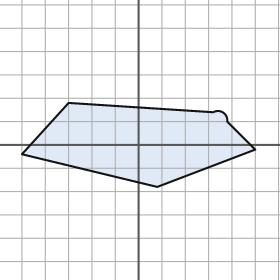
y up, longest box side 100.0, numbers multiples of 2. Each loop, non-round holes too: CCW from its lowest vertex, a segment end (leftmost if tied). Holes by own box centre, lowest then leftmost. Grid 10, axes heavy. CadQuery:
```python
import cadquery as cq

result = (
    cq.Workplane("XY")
    .moveTo(8.0, -18.0)
    .lineTo(50.0, -2.0)
    .lineTo(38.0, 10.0)
    .threePointArc((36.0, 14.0), (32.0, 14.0))
    .lineTo(-30.0, 18.0)
    .lineTo(-50.0, -4.0)
    .close()
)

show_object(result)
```